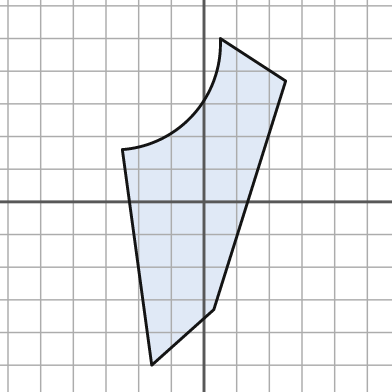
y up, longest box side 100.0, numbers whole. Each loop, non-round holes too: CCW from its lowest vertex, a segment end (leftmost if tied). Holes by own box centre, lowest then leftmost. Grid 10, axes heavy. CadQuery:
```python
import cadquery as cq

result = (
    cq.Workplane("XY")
    .moveTo(-16.0, -50.0)
    .lineTo(3.0, -33.0)
    .lineTo(25.0, 37.0)
    .lineTo(5.0, 50.0)
    .threePointArc((-3.0, 27.0), (-25.0, 16.0))
    .close()
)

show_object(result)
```